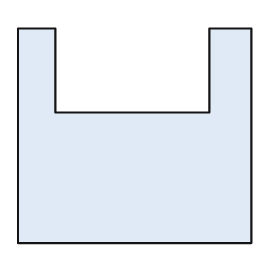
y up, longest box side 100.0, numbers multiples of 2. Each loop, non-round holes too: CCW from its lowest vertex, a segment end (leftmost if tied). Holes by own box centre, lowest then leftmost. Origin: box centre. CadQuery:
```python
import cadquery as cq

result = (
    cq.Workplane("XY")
    .moveTo(-50.0, -46.0)
    .lineTo(50.0, -46.0)
    .lineTo(50.0, 46.0)
    .lineTo(32.0, 46.0)
    .lineTo(32.0, 10.0)
    .lineTo(-34.0, 10.0)
    .lineTo(-34.0, 46.0)
    .lineTo(-50.0, 46.0)
    .close()
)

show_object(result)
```